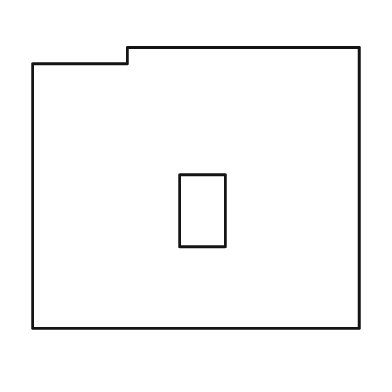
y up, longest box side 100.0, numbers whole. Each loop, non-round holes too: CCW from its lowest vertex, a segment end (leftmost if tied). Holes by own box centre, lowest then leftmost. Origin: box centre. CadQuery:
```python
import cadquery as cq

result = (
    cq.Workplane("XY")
    .moveTo(-50.0, -43.0)
    .lineTo(50.0, -43.0)
    .lineTo(50.0, 43.0)
    .lineTo(-21.0, 43.0)
    .lineTo(-21.0, 38.0)
    .lineTo(-50.0, 38.0)
    .close()
    .moveTo(-5.0, -18.0)
    .lineTo(9.0, -18.0)
    .lineTo(9.0, 4.0)
    .lineTo(-5.0, 4.0)
    .close()
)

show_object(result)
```